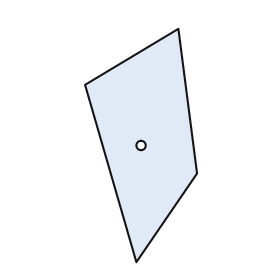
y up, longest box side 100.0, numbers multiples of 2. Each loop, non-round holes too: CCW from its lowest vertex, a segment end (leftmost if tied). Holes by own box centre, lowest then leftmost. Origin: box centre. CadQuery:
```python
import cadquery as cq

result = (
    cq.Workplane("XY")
    .moveTo(-2.0, -50.0)
    .lineTo(24.0, -12.0)
    .lineTo(16.0, 50.0)
    .lineTo(-24.0, 26.0)
    .close()
    .moveTo(0.0, 0.0)
    .circle(2.0)
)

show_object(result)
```